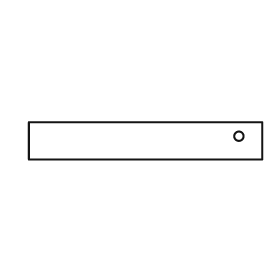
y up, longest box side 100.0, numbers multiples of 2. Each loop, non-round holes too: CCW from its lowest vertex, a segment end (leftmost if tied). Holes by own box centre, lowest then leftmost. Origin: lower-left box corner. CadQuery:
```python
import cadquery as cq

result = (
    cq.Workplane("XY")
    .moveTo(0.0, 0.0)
    .lineTo(100.0, 0.0)
    .lineTo(100.0, 16.0)
    .lineTo(0.0, 16.0)
    .close()
    .moveTo(90.0, 10.0)
    .circle(2.0)
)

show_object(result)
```